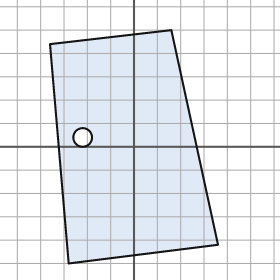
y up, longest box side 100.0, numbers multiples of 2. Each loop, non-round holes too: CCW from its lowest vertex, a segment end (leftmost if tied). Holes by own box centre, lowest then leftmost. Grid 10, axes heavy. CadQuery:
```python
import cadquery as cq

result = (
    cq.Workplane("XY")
    .moveTo(-28.0, -50.0)
    .lineTo(36.0, -42.0)
    .lineTo(16.0, 50.0)
    .lineTo(-36.0, 44.0)
    .close()
    .moveTo(-22.0, 4.0)
    .circle(4.0)
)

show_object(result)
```